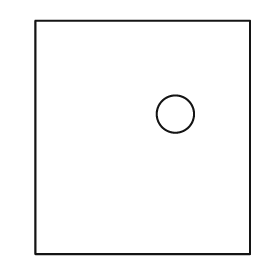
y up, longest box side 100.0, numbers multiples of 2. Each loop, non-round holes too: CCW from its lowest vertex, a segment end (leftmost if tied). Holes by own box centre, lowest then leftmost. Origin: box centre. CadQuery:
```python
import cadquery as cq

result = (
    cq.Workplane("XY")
    .moveTo(-46.0, -50.0)
    .lineTo(46.0, -50.0)
    .lineTo(46.0, 50.0)
    .lineTo(-46.0, 50.0)
    .close()
    .moveTo(14.0, 10.0)
    .circle(8.0)
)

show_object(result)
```